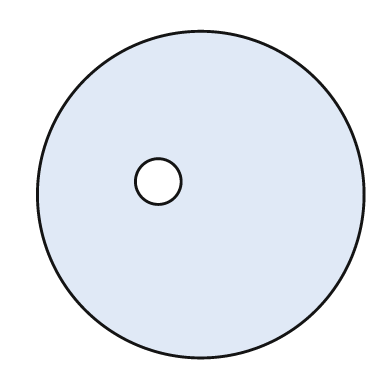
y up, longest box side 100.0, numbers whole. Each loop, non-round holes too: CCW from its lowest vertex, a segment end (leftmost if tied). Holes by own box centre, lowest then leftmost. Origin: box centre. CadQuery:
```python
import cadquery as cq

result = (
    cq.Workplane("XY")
    .moveTo(0.0, 0.0)
    .circle(50.0)
    .moveTo(-13.0, 4.0)
    .circle(7.0)
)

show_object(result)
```